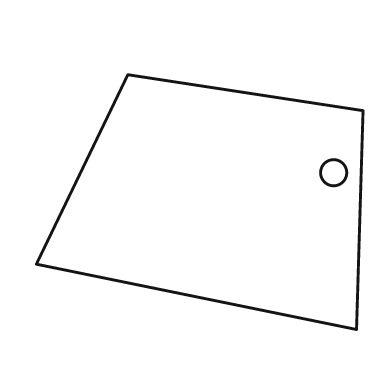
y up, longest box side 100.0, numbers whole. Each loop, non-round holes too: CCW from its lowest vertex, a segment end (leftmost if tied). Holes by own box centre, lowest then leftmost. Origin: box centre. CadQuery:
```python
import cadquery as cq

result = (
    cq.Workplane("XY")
    .moveTo(48.0, -39.0)
    .lineTo(50.0, 28.0)
    .lineTo(-22.0, 39.0)
    .lineTo(-50.0, -19.0)
    .close()
    .moveTo(41.0, 9.0)
    .circle(4.0)
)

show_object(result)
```